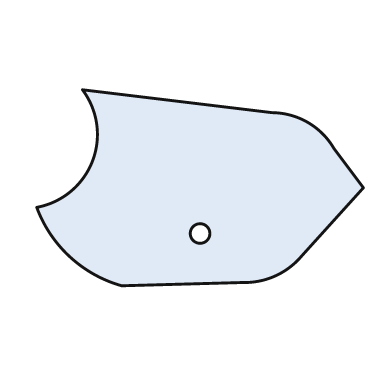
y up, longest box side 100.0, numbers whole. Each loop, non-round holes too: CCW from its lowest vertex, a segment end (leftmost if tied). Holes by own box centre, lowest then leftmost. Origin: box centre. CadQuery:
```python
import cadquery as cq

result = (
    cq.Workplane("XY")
    .moveTo(-24.0, -30.0)
    .lineTo(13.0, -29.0)
    .threePointArc((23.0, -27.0), (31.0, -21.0))
    .lineTo(50.0, 0.0)
    .lineTo(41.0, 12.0)
    .threePointArc((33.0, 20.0), (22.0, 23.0))
    .lineTo(-36.0, 30.0)
    .threePointArc((-33.0, 8.0), (-50.0, -6.0))
    .threePointArc((-40.0, -21.0), (-24.0, -30.0))
    .close()
    .moveTo(0.0, -14.0)
    .circle(3.0)
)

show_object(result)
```